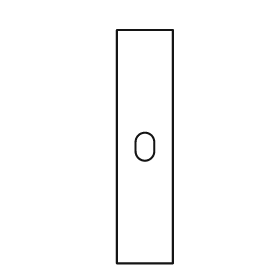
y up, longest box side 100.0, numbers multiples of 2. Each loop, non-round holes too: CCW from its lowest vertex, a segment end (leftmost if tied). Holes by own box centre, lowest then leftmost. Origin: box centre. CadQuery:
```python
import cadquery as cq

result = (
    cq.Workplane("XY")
    .moveTo(-12.0, -50.0)
    .lineTo(12.0, -50.0)
    .lineTo(12.0, 50.0)
    .lineTo(-12.0, 50.0)
    .close()
    .moveTo(-4.0, -2.0)
    .threePointArc((0.0, -6.0), (4.0, -2.0))
    .lineTo(4.0, 2.0)
    .threePointArc((0.0, 6.0), (-4.0, 2.0))
    .close()
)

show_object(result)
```